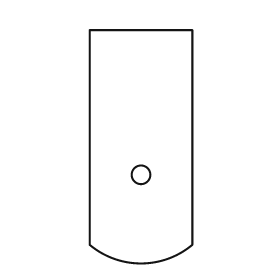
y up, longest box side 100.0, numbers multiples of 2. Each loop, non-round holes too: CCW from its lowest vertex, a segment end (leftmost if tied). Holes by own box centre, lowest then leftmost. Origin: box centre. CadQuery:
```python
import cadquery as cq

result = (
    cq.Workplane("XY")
    .moveTo(-22.0, -42.0)
    .threePointArc((0.0, -50.0), (22.0, -42.0))
    .lineTo(22.0, 50.0)
    .lineTo(-22.0, 50.0)
    .close()
    .moveTo(0.0, -12.0)
    .circle(4.0)
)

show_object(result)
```